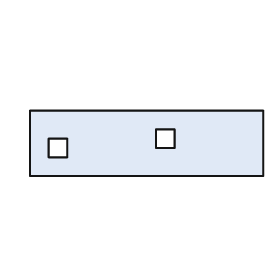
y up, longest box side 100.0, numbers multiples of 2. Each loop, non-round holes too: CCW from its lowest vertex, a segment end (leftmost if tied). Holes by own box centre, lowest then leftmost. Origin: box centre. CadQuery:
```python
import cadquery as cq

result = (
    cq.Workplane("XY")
    .moveTo(-50.0, -14.0)
    .lineTo(50.0, -14.0)
    .lineTo(50.0, 14.0)
    .lineTo(-50.0, 14.0)
    .close()
    .moveTo(-42.0, -6.0)
    .lineTo(-34.0, -6.0)
    .lineTo(-34.0, 2.0)
    .lineTo(-42.0, 2.0)
    .close()
    .moveTo(4.0, -2.0)
    .lineTo(12.0, -2.0)
    .lineTo(12.0, 6.0)
    .lineTo(4.0, 6.0)
    .close()
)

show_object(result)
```